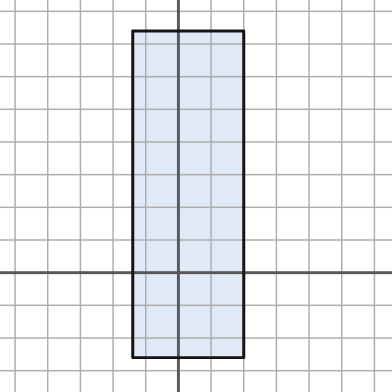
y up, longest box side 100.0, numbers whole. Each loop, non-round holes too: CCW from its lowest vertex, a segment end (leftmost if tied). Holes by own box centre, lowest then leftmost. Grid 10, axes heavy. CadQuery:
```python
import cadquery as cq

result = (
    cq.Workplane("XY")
    .moveTo(-14.0, -26.0)
    .lineTo(20.0, -26.0)
    .lineTo(20.0, 74.0)
    .lineTo(-14.0, 74.0)
    .close()
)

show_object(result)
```